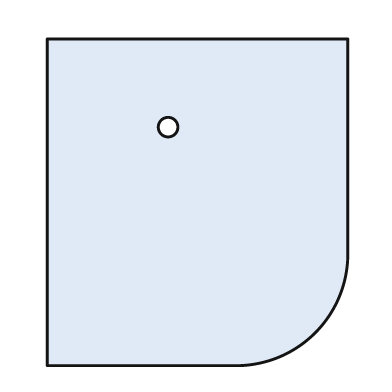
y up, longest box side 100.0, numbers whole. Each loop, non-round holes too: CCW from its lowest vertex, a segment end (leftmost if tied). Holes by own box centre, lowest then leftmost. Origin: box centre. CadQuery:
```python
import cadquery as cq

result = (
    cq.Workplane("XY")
    .moveTo(-46.0, -50.0)
    .lineTo(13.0, -50.0)
    .threePointArc((36.0, -40.0), (46.0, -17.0))
    .lineTo(46.0, 50.0)
    .lineTo(-46.0, 50.0)
    .close()
    .moveTo(-9.0, 23.0)
    .circle(3.0)
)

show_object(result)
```